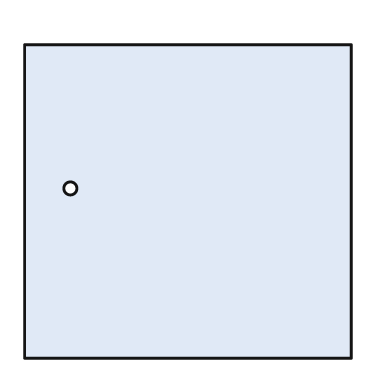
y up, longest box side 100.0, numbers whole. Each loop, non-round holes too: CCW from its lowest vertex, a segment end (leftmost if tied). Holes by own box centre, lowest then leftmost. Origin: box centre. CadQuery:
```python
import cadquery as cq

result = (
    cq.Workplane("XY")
    .moveTo(-50.0, -48.0)
    .lineTo(50.0, -48.0)
    .lineTo(50.0, 48.0)
    .lineTo(-50.0, 48.0)
    .close()
    .moveTo(-36.0, 4.0)
    .circle(2.0)
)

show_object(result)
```